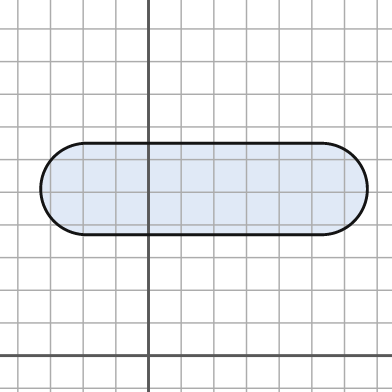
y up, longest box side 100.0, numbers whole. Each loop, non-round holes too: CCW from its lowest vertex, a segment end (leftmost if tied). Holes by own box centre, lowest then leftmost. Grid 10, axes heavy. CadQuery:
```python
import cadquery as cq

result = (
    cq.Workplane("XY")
    .moveTo(-19.0, 37.0)
    .lineTo(53.0, 37.0)
    .threePointArc((67.0, 51.0), (53.0, 65.0))
    .lineTo(-19.0, 65.0)
    .threePointArc((-33.0, 51.0), (-19.0, 37.0))
    .close()
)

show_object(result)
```